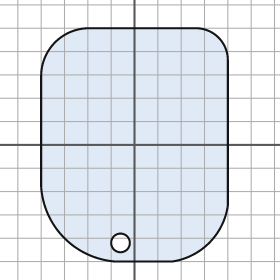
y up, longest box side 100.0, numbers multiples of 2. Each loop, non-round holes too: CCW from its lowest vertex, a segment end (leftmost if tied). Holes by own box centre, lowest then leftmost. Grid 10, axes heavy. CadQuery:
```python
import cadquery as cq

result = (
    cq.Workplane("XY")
    .moveTo(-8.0, -50.0)
    .lineTo(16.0, -50.0)
    .threePointArc((32.0, -42.0), (40.0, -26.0))
    .lineTo(40.0, 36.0)
    .threePointArc((36.0, 46.0), (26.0, 50.0))
    .lineTo(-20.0, 50.0)
    .threePointArc((-34.0, 44.0), (-40.0, 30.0))
    .lineTo(-40.0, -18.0)
    .threePointArc((-30.0, -40.0), (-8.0, -50.0))
    .close()
    .moveTo(-6.0, -42.0)
    .circle(4.0)
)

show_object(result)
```